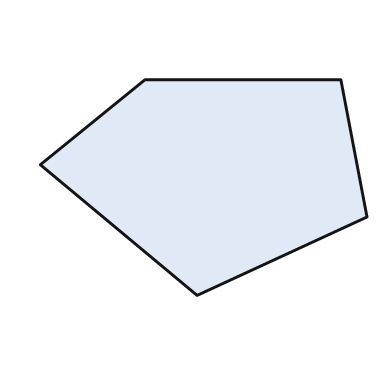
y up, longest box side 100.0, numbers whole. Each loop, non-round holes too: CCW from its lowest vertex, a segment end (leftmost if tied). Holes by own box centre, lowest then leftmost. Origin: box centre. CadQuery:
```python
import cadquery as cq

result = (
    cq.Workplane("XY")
    .moveTo(-2.0, -33.0)
    .lineTo(50.0, -9.0)
    .lineTo(42.0, 33.0)
    .lineTo(-18.0, 33.0)
    .lineTo(-50.0, 7.0)
    .close()
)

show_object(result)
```